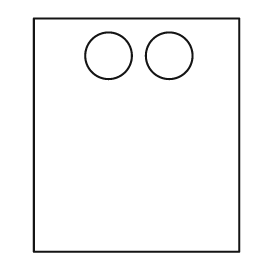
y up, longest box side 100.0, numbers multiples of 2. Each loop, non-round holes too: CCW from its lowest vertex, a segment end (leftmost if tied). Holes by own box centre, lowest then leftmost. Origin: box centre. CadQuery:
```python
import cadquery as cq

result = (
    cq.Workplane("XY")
    .moveTo(-44.0, -50.0)
    .lineTo(44.0, -50.0)
    .lineTo(44.0, 50.0)
    .lineTo(-44.0, 50.0)
    .close()
    .moveTo(-12.0, 34.0)
    .circle(10.0)
    .moveTo(14.0, 34.0)
    .circle(10.0)
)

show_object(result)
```